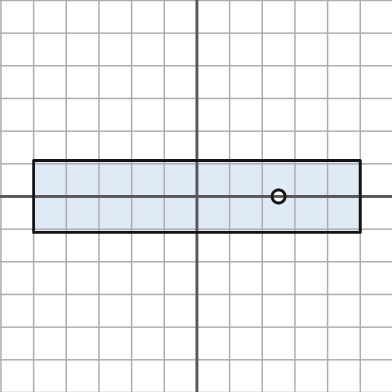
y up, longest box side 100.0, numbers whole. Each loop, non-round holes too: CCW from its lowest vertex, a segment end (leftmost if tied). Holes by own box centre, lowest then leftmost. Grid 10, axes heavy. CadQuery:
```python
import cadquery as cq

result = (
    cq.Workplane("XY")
    .moveTo(-50.0, -11.0)
    .lineTo(50.0, -11.0)
    .lineTo(50.0, 11.0)
    .lineTo(-50.0, 11.0)
    .close()
    .moveTo(25.0, 0.0)
    .circle(2.0)
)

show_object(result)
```